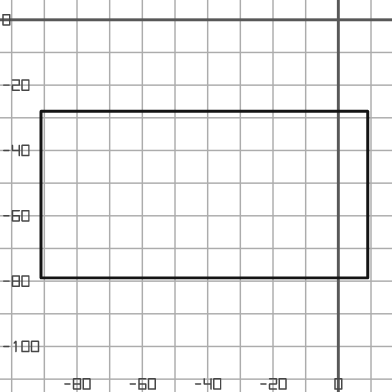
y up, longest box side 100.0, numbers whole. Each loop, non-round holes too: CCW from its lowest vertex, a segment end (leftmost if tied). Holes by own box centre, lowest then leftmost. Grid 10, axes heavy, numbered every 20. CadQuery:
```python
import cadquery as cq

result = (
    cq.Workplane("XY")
    .moveTo(-91.0, -79.0)
    .lineTo(9.0, -79.0)
    .lineTo(9.0, -28.0)
    .lineTo(-91.0, -28.0)
    .close()
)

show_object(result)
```